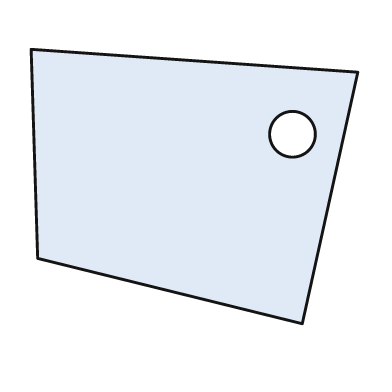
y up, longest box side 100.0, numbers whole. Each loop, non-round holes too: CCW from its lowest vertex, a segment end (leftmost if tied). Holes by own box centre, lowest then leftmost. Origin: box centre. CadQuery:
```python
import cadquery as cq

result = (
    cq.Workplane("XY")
    .moveTo(33.0, -42.0)
    .lineTo(50.0, 35.0)
    .lineTo(-50.0, 42.0)
    .lineTo(-48.0, -22.0)
    .close()
    .moveTo(30.0, 16.0)
    .circle(7.0)
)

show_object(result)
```